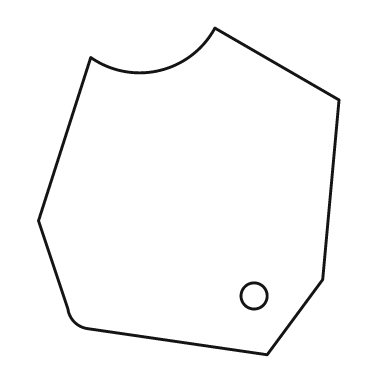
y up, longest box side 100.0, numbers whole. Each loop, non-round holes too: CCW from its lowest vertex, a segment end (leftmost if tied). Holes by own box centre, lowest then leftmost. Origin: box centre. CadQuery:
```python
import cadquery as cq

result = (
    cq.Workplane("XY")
    .moveTo(24.0, -50.0)
    .lineTo(41.0, -27.0)
    .lineTo(46.0, 28.0)
    .lineTo(8.0, 50.0)
    .threePointArc((-9.0, 37.0), (-30.0, 41.0))
    .lineTo(-46.0, -9.0)
    .lineTo(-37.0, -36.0)
    .threePointArc((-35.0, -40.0), (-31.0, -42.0))
    .close()
    .moveTo(20.0, -32.0)
    .circle(4.0)
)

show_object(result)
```